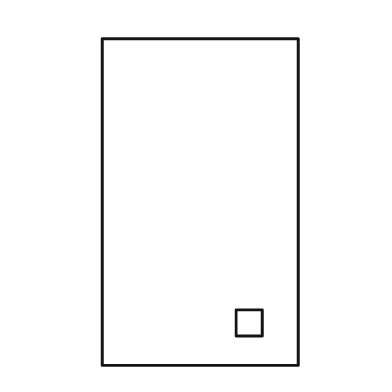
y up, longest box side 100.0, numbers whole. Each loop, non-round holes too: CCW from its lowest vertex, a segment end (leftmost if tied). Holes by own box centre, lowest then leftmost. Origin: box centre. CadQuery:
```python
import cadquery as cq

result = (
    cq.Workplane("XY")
    .moveTo(-30.0, -50.0)
    .lineTo(30.0, -50.0)
    .lineTo(30.0, 50.0)
    .lineTo(-30.0, 50.0)
    .close()
    .moveTo(11.0, -41.0)
    .lineTo(19.0, -41.0)
    .lineTo(19.0, -33.0)
    .lineTo(11.0, -33.0)
    .close()
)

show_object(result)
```